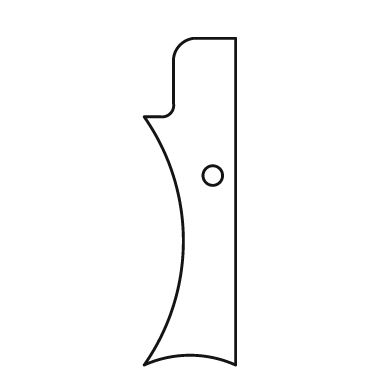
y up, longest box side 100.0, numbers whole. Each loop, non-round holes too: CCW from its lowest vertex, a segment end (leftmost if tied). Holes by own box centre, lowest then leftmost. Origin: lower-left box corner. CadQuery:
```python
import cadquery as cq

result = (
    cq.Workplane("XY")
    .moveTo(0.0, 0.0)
    .threePointArc((14.0, 3.0), (28.0, 0.0))
    .lineTo(28.0, 100.0)
    .lineTo(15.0, 100.0)
    .threePointArc((11.0, 98.0), (9.0, 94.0))
    .lineTo(9.0, 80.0)
    .threePointArc((8.0, 77.0), (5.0, 76.0))
    .lineTo(0.0, 76.0)
    .threePointArc((12.0, 38.0), (0.0, 0.0))
    .close()
    .moveTo(21.0, 58.0)
    .circle(3.0)
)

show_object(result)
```